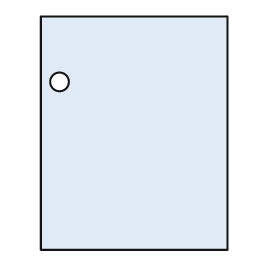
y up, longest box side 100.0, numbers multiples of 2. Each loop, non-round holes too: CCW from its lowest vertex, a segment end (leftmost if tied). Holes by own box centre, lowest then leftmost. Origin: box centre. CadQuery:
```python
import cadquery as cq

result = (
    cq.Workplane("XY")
    .moveTo(-40.0, -50.0)
    .lineTo(40.0, -50.0)
    .lineTo(40.0, 50.0)
    .lineTo(-40.0, 50.0)
    .close()
    .moveTo(-32.0, 22.0)
    .circle(4.0)
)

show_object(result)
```